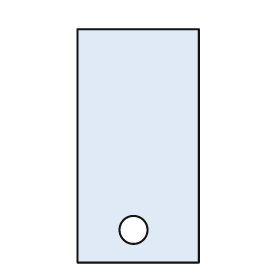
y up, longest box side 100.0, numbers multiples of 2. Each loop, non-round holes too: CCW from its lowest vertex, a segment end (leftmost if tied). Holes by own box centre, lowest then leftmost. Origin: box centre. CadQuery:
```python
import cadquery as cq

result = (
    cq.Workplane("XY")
    .moveTo(-26.0, -50.0)
    .lineTo(26.0, -50.0)
    .lineTo(26.0, 50.0)
    .lineTo(-26.0, 50.0)
    .close()
    .moveTo(-2.0, -36.0)
    .circle(6.0)
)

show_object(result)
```